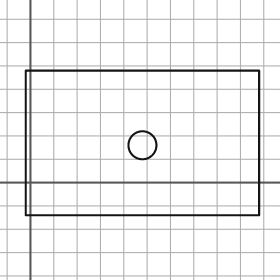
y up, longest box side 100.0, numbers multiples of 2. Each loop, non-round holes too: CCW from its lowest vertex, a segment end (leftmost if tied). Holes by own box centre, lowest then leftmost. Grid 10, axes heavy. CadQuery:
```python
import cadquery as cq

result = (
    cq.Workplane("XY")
    .moveTo(-2.0, -14.0)
    .lineTo(98.0, -14.0)
    .lineTo(98.0, 48.0)
    .lineTo(-2.0, 48.0)
    .close()
    .moveTo(48.0, 16.0)
    .circle(6.0)
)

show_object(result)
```